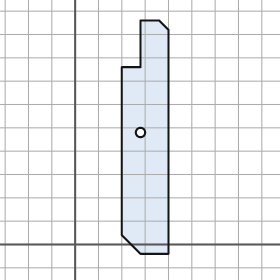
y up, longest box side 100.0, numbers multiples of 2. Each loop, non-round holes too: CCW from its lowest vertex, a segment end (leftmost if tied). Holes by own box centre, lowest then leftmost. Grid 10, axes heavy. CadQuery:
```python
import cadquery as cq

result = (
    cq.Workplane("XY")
    .moveTo(28.0, -4.0)
    .lineTo(40.0, -4.0)
    .lineTo(40.0, 92.0)
    .lineTo(36.0, 96.0)
    .lineTo(28.0, 96.0)
    .lineTo(28.0, 76.0)
    .lineTo(20.0, 76.0)
    .lineTo(20.0, 4.0)
    .close()
    .moveTo(28.0, 48.0)
    .circle(2.0)
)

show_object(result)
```